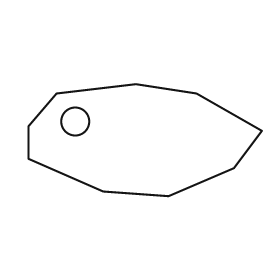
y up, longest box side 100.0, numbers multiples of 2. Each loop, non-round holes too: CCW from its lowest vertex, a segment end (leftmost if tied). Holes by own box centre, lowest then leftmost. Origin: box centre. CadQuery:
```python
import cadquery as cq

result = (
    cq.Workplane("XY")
    .moveTo(10.0, -24.0)
    .lineTo(38.0, -12.0)
    .lineTo(50.0, 4.0)
    .lineTo(22.0, 20.0)
    .lineTo(-4.0, 24.0)
    .lineTo(-38.0, 20.0)
    .lineTo(-50.0, 6.0)
    .lineTo(-50.0, -8.0)
    .lineTo(-18.0, -22.0)
    .close()
    .moveTo(-30.0, 8.0)
    .circle(6.0)
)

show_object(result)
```